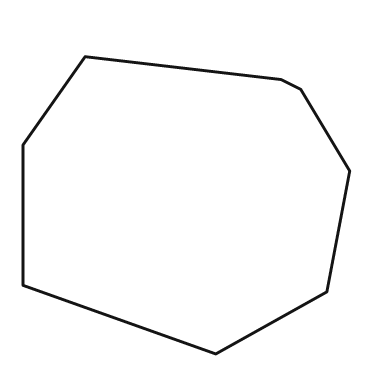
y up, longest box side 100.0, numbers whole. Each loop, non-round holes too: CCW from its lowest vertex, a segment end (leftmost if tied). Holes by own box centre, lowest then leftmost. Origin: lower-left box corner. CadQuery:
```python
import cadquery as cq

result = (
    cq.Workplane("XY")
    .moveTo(59.0, 0.0)
    .lineTo(93.0, 19.0)
    .lineTo(100.0, 56.0)
    .lineTo(85.0, 81.0)
    .lineTo(79.0, 84.0)
    .lineTo(19.0, 91.0)
    .lineTo(0.0, 64.0)
    .lineTo(0.0, 21.0)
    .close()
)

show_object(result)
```